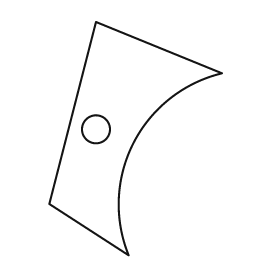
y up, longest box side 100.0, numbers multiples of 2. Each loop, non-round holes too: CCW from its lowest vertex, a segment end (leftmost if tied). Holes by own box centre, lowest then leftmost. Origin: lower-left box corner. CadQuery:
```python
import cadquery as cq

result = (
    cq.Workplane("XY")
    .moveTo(34.0, 0.0)
    .threePointArc((36.0, 48.0), (74.0, 78.0))
    .lineTo(20.0, 100.0)
    .lineTo(0.0, 22.0)
    .close()
    .moveTo(20.0, 54.0)
    .circle(6.0)
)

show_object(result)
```